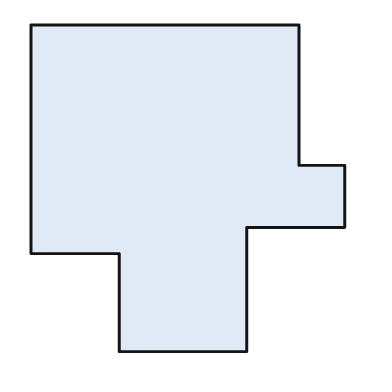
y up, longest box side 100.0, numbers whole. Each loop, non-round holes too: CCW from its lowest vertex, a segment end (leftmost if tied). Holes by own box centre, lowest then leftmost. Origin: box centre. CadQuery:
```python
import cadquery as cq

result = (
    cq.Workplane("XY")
    .moveTo(-21.0, -50.0)
    .lineTo(18.0, -50.0)
    .lineTo(18.0, -12.0)
    .lineTo(48.0, -12.0)
    .lineTo(48.0, 7.0)
    .lineTo(34.0, 7.0)
    .lineTo(34.0, 50.0)
    .lineTo(-48.0, 50.0)
    .lineTo(-48.0, -20.0)
    .lineTo(-21.0, -20.0)
    .close()
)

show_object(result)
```